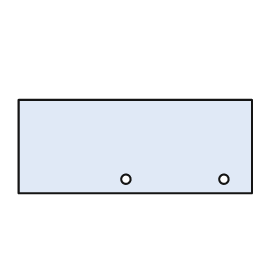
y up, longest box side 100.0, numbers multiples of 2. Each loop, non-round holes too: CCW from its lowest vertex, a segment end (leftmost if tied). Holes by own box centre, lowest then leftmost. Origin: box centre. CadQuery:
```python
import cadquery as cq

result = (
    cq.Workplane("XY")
    .moveTo(-50.0, -20.0)
    .lineTo(50.0, -20.0)
    .lineTo(50.0, 20.0)
    .lineTo(-50.0, 20.0)
    .close()
    .moveTo(-4.0, -14.0)
    .circle(2.0)
    .moveTo(38.0, -14.0)
    .circle(2.0)
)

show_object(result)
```